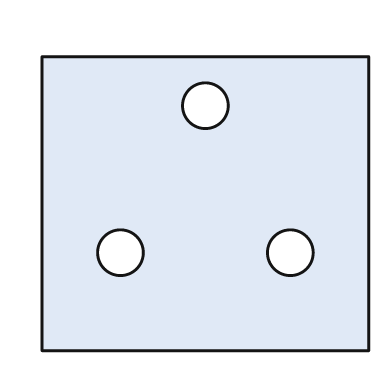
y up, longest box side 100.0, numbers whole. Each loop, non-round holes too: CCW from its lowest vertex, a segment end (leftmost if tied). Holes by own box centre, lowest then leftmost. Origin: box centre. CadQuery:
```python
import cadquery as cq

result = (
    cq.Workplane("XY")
    .moveTo(-50.0, -45.0)
    .lineTo(50.0, -45.0)
    .lineTo(50.0, 45.0)
    .lineTo(-50.0, 45.0)
    .close()
    .moveTo(-26.0, -15.0)
    .circle(7.0)
    .moveTo(26.0, -15.0)
    .circle(7.0)
    .moveTo(0.0, 30.0)
    .circle(7.0)
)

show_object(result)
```